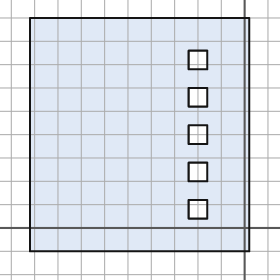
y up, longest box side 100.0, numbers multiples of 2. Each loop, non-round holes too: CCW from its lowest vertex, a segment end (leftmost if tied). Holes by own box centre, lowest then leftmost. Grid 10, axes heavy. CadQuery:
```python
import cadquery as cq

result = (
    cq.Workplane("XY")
    .moveTo(-92.0, -10.0)
    .lineTo(2.0, -10.0)
    .lineTo(2.0, 90.0)
    .lineTo(-92.0, 90.0)
    .close()
    .moveTo(-24.0, 4.0)
    .lineTo(-16.0, 4.0)
    .lineTo(-16.0, 12.0)
    .lineTo(-24.0, 12.0)
    .close()
    .moveTo(-24.0, 20.0)
    .lineTo(-16.0, 20.0)
    .lineTo(-16.0, 28.0)
    .lineTo(-24.0, 28.0)
    .close()
    .moveTo(-24.0, 36.0)
    .lineTo(-16.0, 36.0)
    .lineTo(-16.0, 44.0)
    .lineTo(-24.0, 44.0)
    .close()
    .moveTo(-24.0, 52.0)
    .lineTo(-16.0, 52.0)
    .lineTo(-16.0, 60.0)
    .lineTo(-24.0, 60.0)
    .close()
    .moveTo(-24.0, 68.0)
    .lineTo(-16.0, 68.0)
    .lineTo(-16.0, 76.0)
    .lineTo(-24.0, 76.0)
    .close()
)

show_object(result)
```